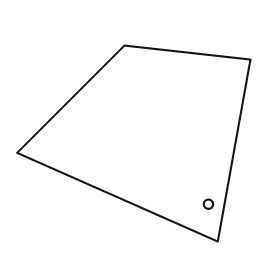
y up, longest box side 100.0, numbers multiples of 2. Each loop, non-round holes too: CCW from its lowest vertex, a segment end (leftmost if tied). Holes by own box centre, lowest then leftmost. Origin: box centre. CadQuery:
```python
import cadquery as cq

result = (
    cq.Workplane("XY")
    .moveTo(36.0, -42.0)
    .lineTo(50.0, 36.0)
    .lineTo(-4.0, 42.0)
    .lineTo(-50.0, -4.0)
    .close()
    .moveTo(32.0, -26.0)
    .circle(2.0)
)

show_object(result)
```